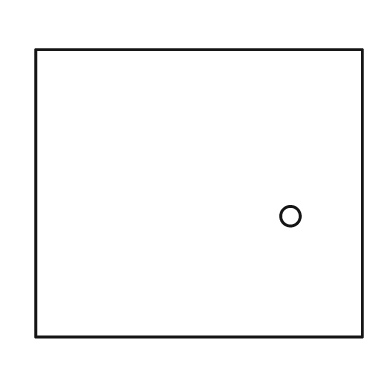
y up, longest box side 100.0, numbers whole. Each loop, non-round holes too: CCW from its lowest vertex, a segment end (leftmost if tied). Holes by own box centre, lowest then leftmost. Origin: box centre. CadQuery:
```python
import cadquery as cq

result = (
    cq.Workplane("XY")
    .moveTo(-50.0, -44.0)
    .lineTo(50.0, -44.0)
    .lineTo(50.0, 44.0)
    .lineTo(-50.0, 44.0)
    .close()
    .moveTo(28.0, -7.0)
    .circle(3.0)
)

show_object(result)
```